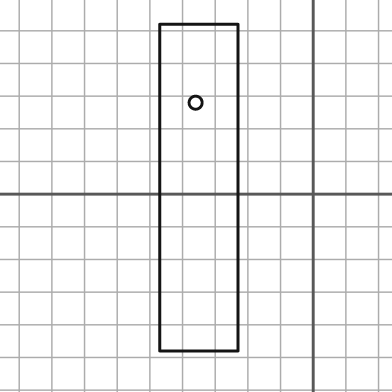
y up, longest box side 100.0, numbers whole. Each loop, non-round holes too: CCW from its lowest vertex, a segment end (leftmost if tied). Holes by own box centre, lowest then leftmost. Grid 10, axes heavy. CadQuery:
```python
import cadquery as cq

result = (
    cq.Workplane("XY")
    .moveTo(-47.0, -48.0)
    .lineTo(-23.0, -48.0)
    .lineTo(-23.0, 52.0)
    .lineTo(-47.0, 52.0)
    .close()
    .moveTo(-36.0, 28.0)
    .circle(2.0)
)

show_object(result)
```